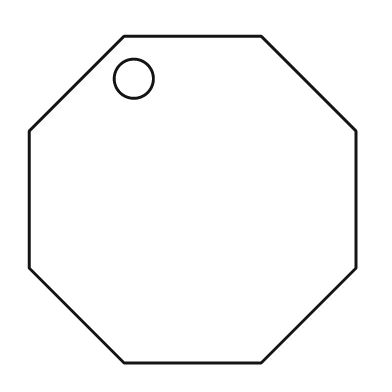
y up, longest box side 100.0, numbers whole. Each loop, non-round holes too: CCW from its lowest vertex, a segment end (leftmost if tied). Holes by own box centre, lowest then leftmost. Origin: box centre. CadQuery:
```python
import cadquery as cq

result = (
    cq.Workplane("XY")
    .moveTo(-21.0, -50.0)
    .lineTo(21.0, -50.0)
    .lineTo(50.0, -21.0)
    .lineTo(50.0, 21.0)
    .lineTo(21.0, 50.0)
    .lineTo(-21.0, 50.0)
    .lineTo(-50.0, 21.0)
    .lineTo(-50.0, -21.0)
    .close()
    .moveTo(-18.0, 37.0)
    .circle(6.0)
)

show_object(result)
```